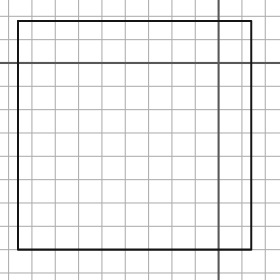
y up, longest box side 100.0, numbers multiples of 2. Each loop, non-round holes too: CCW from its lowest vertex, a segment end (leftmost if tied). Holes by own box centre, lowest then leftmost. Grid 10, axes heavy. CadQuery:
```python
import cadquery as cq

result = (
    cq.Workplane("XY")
    .moveTo(-86.0, -80.0)
    .lineTo(14.0, -80.0)
    .lineTo(14.0, 18.0)
    .lineTo(-86.0, 18.0)
    .close()
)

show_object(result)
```